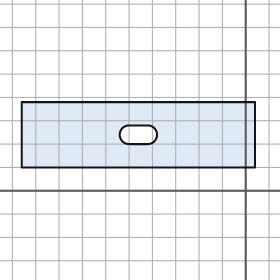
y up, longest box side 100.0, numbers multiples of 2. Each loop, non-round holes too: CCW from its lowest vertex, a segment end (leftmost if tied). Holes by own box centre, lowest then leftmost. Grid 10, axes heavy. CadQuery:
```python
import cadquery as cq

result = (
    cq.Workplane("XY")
    .moveTo(-96.0, 10.0)
    .lineTo(4.0, 10.0)
    .lineTo(4.0, 38.0)
    .lineTo(-96.0, 38.0)
    .close()
    .moveTo(-50.0, 20.0)
    .lineTo(-42.0, 20.0)
    .threePointArc((-38.0, 24.0), (-42.0, 28.0))
    .lineTo(-50.0, 28.0)
    .threePointArc((-54.0, 24.0), (-50.0, 20.0))
    .close()
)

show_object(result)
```